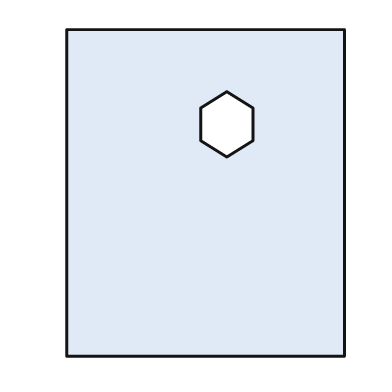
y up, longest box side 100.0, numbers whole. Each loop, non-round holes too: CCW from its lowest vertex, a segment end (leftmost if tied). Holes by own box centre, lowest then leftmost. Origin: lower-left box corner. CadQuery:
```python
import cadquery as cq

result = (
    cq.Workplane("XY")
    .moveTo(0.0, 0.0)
    .lineTo(85.0, 0.0)
    .lineTo(85.0, 100.0)
    .lineTo(0.0, 100.0)
    .close()
    .moveTo(49.0, 61.0)
    .lineTo(57.0, 66.0)
    .lineTo(57.0, 76.0)
    .lineTo(49.0, 81.0)
    .lineTo(41.0, 76.0)
    .lineTo(41.0, 66.0)
    .close()
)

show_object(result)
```